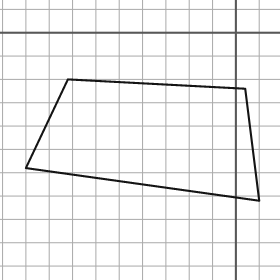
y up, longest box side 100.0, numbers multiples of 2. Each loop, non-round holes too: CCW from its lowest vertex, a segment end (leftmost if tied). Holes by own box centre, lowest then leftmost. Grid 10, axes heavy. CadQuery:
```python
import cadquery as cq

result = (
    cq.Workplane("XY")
    .moveTo(10.0, -72.0)
    .lineTo(4.0, -24.0)
    .lineTo(-72.0, -20.0)
    .lineTo(-90.0, -58.0)
    .close()
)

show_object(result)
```